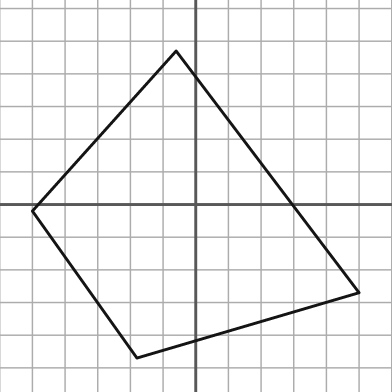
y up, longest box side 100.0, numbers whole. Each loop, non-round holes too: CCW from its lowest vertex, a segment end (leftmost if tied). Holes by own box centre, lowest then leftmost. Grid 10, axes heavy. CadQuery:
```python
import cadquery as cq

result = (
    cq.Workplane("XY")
    .moveTo(-18.0, -47.0)
    .lineTo(50.0, -27.0)
    .lineTo(-6.0, 47.0)
    .lineTo(-50.0, -2.0)
    .close()
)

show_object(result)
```